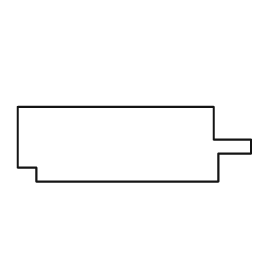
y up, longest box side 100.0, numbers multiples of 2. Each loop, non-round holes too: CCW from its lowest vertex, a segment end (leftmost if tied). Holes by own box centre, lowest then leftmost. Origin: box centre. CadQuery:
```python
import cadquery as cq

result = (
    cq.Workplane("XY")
    .moveTo(-42.0, -16.0)
    .lineTo(36.0, -16.0)
    .lineTo(36.0, -4.0)
    .lineTo(50.0, -4.0)
    .lineTo(50.0, 2.0)
    .lineTo(34.0, 2.0)
    .lineTo(34.0, 16.0)
    .lineTo(-50.0, 16.0)
    .lineTo(-50.0, -10.0)
    .lineTo(-42.0, -10.0)
    .close()
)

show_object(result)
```